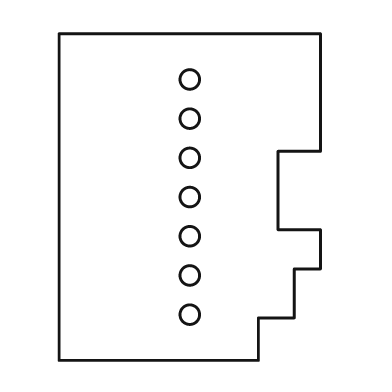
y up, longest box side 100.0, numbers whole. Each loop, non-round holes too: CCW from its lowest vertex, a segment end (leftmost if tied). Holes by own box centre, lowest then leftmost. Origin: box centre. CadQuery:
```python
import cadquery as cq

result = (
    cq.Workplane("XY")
    .moveTo(-40.0, -50.0)
    .lineTo(21.0, -50.0)
    .lineTo(21.0, -37.0)
    .lineTo(32.0, -37.0)
    .lineTo(32.0, -22.0)
    .lineTo(40.0, -22.0)
    .lineTo(40.0, -10.0)
    .lineTo(27.0, -10.0)
    .lineTo(27.0, 14.0)
    .lineTo(40.0, 14.0)
    .lineTo(40.0, 50.0)
    .lineTo(-40.0, 50.0)
    .close()
    .moveTo(0.0, -36.0)
    .circle(3.0)
    .moveTo(0.0, -24.0)
    .circle(3.0)
    .moveTo(0.0, -12.0)
    .circle(3.0)
    .moveTo(0.0, 0.0)
    .circle(3.0)
    .moveTo(0.0, 12.0)
    .circle(3.0)
    .moveTo(0.0, 24.0)
    .circle(3.0)
    .moveTo(0.0, 36.0)
    .circle(3.0)
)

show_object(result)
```